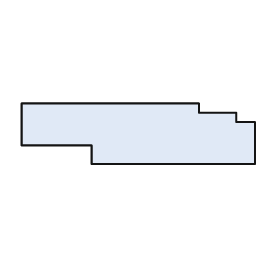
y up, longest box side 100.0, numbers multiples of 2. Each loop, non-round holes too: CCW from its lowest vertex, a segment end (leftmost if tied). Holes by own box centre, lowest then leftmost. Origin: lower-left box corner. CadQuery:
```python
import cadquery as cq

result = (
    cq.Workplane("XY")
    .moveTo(30.0, 0.0)
    .lineTo(100.0, 0.0)
    .lineTo(100.0, 18.0)
    .lineTo(92.0, 18.0)
    .lineTo(92.0, 22.0)
    .lineTo(76.0, 22.0)
    .lineTo(76.0, 26.0)
    .lineTo(0.0, 26.0)
    .lineTo(0.0, 8.0)
    .lineTo(30.0, 8.0)
    .close()
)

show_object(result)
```